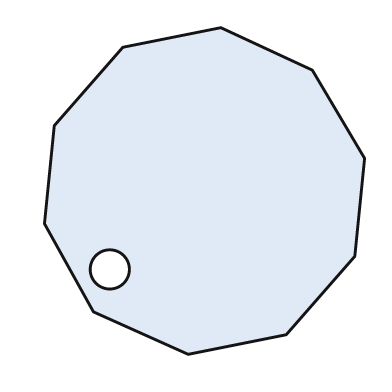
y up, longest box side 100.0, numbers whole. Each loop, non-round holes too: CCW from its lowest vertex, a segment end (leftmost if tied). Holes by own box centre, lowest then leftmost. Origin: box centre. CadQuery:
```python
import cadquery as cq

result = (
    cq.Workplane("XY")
    .moveTo(-5.0, -50.0)
    .lineTo(25.0, -44.0)
    .lineTo(46.0, -20.0)
    .lineTo(49.0, 10.0)
    .lineTo(33.0, 37.0)
    .lineTo(5.0, 50.0)
    .lineTo(-25.0, 44.0)
    .lineTo(-46.0, 20.0)
    .lineTo(-49.0, -10.0)
    .lineTo(-34.0, -37.0)
    .close()
    .moveTo(-29.0, -24.0)
    .circle(6.0)
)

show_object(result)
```